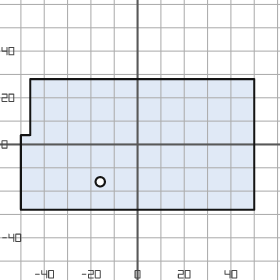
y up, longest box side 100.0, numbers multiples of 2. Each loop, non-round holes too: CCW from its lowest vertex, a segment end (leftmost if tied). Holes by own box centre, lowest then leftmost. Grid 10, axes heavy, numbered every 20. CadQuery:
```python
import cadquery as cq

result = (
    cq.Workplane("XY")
    .moveTo(-50.0, -28.0)
    .lineTo(50.0, -28.0)
    .lineTo(50.0, 28.0)
    .lineTo(-46.0, 28.0)
    .lineTo(-46.0, 4.0)
    .lineTo(-50.0, 4.0)
    .close()
    .moveTo(-16.0, -16.0)
    .circle(2.0)
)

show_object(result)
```